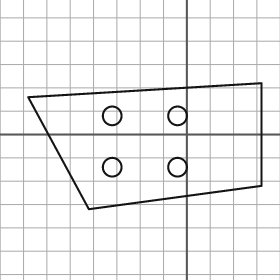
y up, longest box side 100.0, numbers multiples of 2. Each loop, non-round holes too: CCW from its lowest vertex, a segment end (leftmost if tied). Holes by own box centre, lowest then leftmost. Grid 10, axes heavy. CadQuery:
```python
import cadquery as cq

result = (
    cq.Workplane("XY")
    .moveTo(-42.0, -32.0)
    .lineTo(32.0, -22.0)
    .lineTo(32.0, 22.0)
    .lineTo(-68.0, 16.0)
    .close()
    .moveTo(-32.0, -14.0)
    .circle(4.0)
    .moveTo(-4.0, -14.0)
    .circle(4.0)
    .moveTo(-32.0, 8.0)
    .circle(4.0)
    .moveTo(-4.0, 8.0)
    .circle(4.0)
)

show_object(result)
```